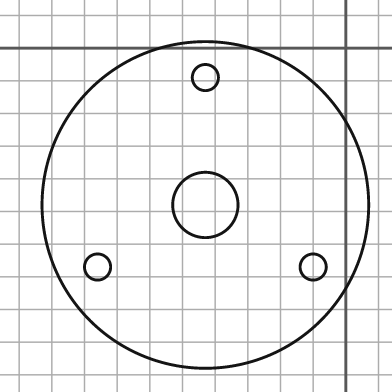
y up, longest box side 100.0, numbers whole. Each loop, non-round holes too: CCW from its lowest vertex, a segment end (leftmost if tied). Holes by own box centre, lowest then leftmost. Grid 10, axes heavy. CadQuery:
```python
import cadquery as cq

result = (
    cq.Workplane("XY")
    .moveTo(-43.0, -48.0)
    .circle(50.0)
    .moveTo(-76.0, -67.0)
    .circle(4.0)
    .moveTo(-10.0, -67.0)
    .circle(4.0)
    .moveTo(-43.0, -48.0)
    .circle(10.0)
    .moveTo(-43.0, -9.0)
    .circle(4.0)
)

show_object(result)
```